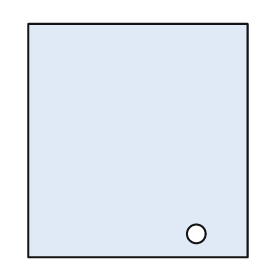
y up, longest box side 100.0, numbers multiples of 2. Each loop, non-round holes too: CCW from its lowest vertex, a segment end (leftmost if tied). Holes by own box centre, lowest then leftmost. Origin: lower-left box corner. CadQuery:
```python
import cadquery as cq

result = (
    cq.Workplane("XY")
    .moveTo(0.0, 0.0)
    .lineTo(94.0, 0.0)
    .lineTo(94.0, 100.0)
    .lineTo(0.0, 100.0)
    .close()
    .moveTo(72.0, 10.0)
    .circle(4.0)
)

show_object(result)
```